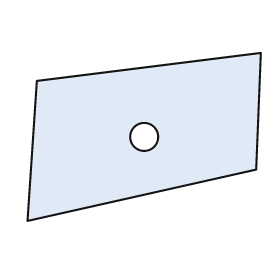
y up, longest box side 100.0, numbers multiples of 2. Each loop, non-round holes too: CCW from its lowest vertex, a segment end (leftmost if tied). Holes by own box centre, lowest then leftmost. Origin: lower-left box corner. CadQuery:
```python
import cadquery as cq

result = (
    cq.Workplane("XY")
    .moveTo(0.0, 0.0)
    .lineTo(98.0, 22.0)
    .lineTo(100.0, 72.0)
    .lineTo(4.0, 60.0)
    .close()
    .moveTo(50.0, 36.0)
    .circle(6.0)
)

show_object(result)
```